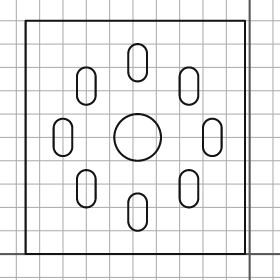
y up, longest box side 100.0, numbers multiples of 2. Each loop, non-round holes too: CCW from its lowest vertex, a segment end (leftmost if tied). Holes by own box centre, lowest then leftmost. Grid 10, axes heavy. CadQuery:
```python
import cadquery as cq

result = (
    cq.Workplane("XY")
    .moveTo(-96.0, 0.0)
    .lineTo(-2.0, 0.0)
    .lineTo(-2.0, 100.0)
    .lineTo(-96.0, 100.0)
    .close()
    .moveTo(-52.0, 14.0)
    .threePointArc((-48.0, 10.0), (-44.0, 14.0))
    .lineTo(-44.0, 22.0)
    .threePointArc((-48.0, 26.0), (-52.0, 22.0))
    .close()
    .moveTo(-74.0, 24.0)
    .threePointArc((-70.0, 20.0), (-66.0, 24.0))
    .lineTo(-66.0, 32.0)
    .threePointArc((-70.0, 36.0), (-74.0, 32.0))
    .close()
    .moveTo(-30.0, 24.0)
    .threePointArc((-26.0, 20.0), (-22.0, 24.0))
    .lineTo(-22.0, 32.0)
    .threePointArc((-26.0, 36.0), (-30.0, 32.0))
    .close()
    .moveTo(-84.0, 46.0)
    .threePointArc((-80.0, 42.0), (-76.0, 46.0))
    .lineTo(-76.0, 54.0)
    .threePointArc((-80.0, 58.0), (-84.0, 54.0))
    .close()
    .moveTo(-48.0, 50.0)
    .circle(10.0)
    .moveTo(-20.0, 46.0)
    .threePointArc((-16.0, 42.0), (-12.0, 46.0))
    .lineTo(-12.0, 54.0)
    .threePointArc((-16.0, 58.0), (-20.0, 54.0))
    .close()
    .moveTo(-74.0, 68.0)
    .threePointArc((-70.0, 64.0), (-66.0, 68.0))
    .lineTo(-66.0, 76.0)
    .threePointArc((-70.0, 80.0), (-74.0, 76.0))
    .close()
    .moveTo(-30.0, 68.0)
    .threePointArc((-26.0, 64.0), (-22.0, 68.0))
    .lineTo(-22.0, 76.0)
    .threePointArc((-26.0, 80.0), (-30.0, 76.0))
    .close()
    .moveTo(-52.0, 78.0)
    .threePointArc((-48.0, 74.0), (-44.0, 78.0))
    .lineTo(-44.0, 86.0)
    .threePointArc((-48.0, 90.0), (-52.0, 86.0))
    .close()
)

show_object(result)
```